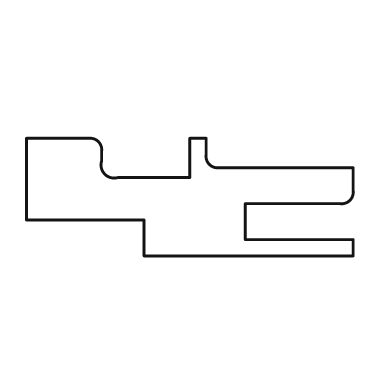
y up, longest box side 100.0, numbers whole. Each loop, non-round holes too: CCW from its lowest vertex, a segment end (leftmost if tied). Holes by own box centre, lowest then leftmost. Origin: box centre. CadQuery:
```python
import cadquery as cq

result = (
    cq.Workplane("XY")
    .moveTo(-14.0, -18.0)
    .lineTo(50.0, -18.0)
    .lineTo(50.0, -13.0)
    .lineTo(17.0, -13.0)
    .lineTo(17.0, -2.0)
    .lineTo(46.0, -2.0)
    .threePointArc((49.0, -1.0), (50.0, 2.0))
    .lineTo(50.0, 9.0)
    .lineTo(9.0, 9.0)
    .threePointArc((6.0, 10.0), (5.0, 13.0))
    .lineTo(5.0, 18.0)
    .lineTo(0.0, 18.0)
    .lineTo(0.0, 6.0)
    .lineTo(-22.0, 6.0)
    .threePointArc((-26.0, 7.0), (-27.0, 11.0))
    .lineTo(-27.0, 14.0)
    .threePointArc((-28.0, 17.0), (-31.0, 18.0))
    .lineTo(-50.0, 18.0)
    .lineTo(-50.0, -7.0)
    .lineTo(-14.0, -7.0)
    .close()
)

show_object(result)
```